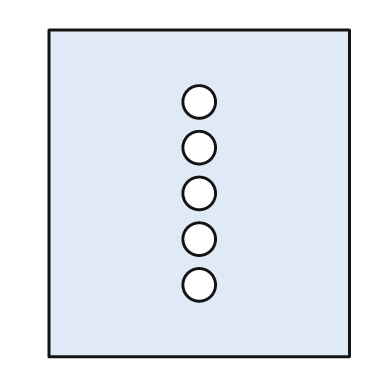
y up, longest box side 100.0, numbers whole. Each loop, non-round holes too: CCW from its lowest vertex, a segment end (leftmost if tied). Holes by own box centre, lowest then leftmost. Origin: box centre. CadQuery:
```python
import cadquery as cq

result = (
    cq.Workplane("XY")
    .moveTo(-46.0, -50.0)
    .lineTo(46.0, -50.0)
    .lineTo(46.0, 50.0)
    .lineTo(-46.0, 50.0)
    .close()
    .moveTo(0.0, -28.0)
    .circle(5.0)
    .moveTo(0.0, -14.0)
    .circle(5.0)
    .moveTo(0.0, 0.0)
    .circle(5.0)
    .moveTo(0.0, 14.0)
    .circle(5.0)
    .moveTo(0.0, 28.0)
    .circle(5.0)
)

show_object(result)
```